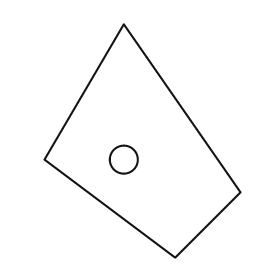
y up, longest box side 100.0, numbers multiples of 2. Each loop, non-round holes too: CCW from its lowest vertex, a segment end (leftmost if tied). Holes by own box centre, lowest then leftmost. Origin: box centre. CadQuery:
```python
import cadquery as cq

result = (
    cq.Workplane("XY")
    .moveTo(14.0, -50.0)
    .lineTo(42.0, -22.0)
    .lineTo(-8.0, 50.0)
    .lineTo(-42.0, -8.0)
    .close()
    .moveTo(-8.0, -8.0)
    .circle(6.0)
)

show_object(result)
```